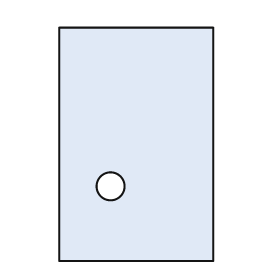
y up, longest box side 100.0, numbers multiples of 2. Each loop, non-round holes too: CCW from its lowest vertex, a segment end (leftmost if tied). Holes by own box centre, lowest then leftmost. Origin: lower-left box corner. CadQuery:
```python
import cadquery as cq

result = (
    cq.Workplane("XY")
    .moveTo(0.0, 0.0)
    .lineTo(66.0, 0.0)
    .lineTo(66.0, 100.0)
    .lineTo(0.0, 100.0)
    .close()
    .moveTo(22.0, 32.0)
    .circle(6.0)
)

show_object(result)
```